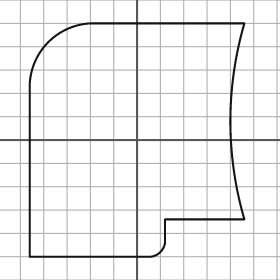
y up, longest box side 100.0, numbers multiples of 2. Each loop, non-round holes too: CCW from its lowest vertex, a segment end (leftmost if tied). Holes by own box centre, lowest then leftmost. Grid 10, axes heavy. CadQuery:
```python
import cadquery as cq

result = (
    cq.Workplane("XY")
    .moveTo(-46.0, -50.0)
    .lineTo(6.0, -50.0)
    .threePointArc((10.0, -48.0), (12.0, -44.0))
    .lineTo(12.0, -34.0)
    .lineTo(46.0, -34.0)
    .threePointArc((40.0, 8.0), (46.0, 50.0))
    .lineTo(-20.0, 50.0)
    .threePointArc((-38.0, 42.0), (-46.0, 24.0))
    .close()
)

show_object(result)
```